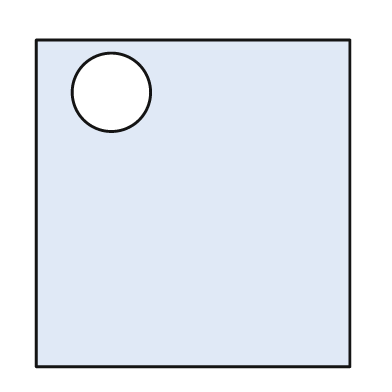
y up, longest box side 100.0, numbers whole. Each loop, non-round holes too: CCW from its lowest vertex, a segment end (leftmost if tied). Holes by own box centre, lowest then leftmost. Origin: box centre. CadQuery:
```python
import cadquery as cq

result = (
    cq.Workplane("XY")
    .moveTo(-48.0, -50.0)
    .lineTo(48.0, -50.0)
    .lineTo(48.0, 50.0)
    .lineTo(-48.0, 50.0)
    .close()
    .moveTo(-25.0, 34.0)
    .circle(12.0)
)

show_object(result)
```